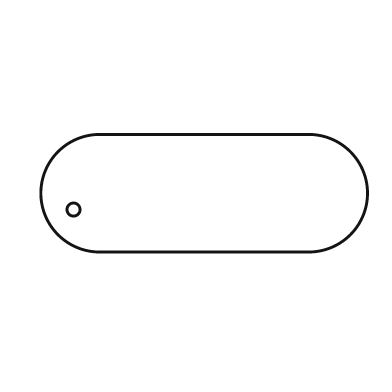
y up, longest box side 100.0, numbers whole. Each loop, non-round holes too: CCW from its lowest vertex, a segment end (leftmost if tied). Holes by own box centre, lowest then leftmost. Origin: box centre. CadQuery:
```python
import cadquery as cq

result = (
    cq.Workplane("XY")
    .moveTo(-32.0, -18.0)
    .lineTo(32.0, -18.0)
    .threePointArc((50.0, 0.0), (32.0, 18.0))
    .lineTo(-32.0, 18.0)
    .threePointArc((-50.0, 0.0), (-32.0, -18.0))
    .close()
    .moveTo(-40.0, -5.0)
    .circle(2.0)
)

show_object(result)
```